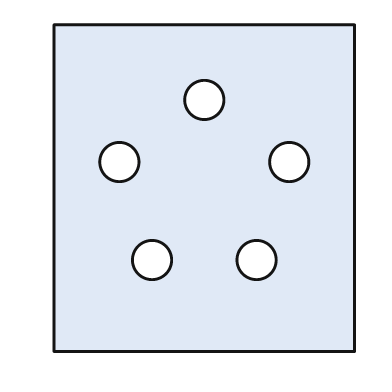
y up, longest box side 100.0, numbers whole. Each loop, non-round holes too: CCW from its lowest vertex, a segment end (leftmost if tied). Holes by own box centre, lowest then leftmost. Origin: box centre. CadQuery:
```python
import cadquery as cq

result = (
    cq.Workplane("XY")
    .moveTo(-46.0, -50.0)
    .lineTo(46.0, -50.0)
    .lineTo(46.0, 50.0)
    .lineTo(-46.0, 50.0)
    .close()
    .moveTo(-16.0, -22.0)
    .circle(6.0)
    .moveTo(16.0, -22.0)
    .circle(6.0)
    .moveTo(-26.0, 8.0)
    .circle(6.0)
    .moveTo(26.0, 8.0)
    .circle(6.0)
    .moveTo(0.0, 27.0)
    .circle(6.0)
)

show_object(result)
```